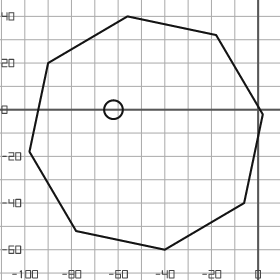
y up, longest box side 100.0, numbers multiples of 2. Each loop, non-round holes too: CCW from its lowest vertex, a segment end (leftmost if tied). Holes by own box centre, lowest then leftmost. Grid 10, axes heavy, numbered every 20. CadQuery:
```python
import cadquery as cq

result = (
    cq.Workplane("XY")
    .moveTo(-40.0, -60.0)
    .lineTo(-6.0, -40.0)
    .lineTo(2.0, -2.0)
    .lineTo(-18.0, 32.0)
    .lineTo(-56.0, 40.0)
    .lineTo(-90.0, 20.0)
    .lineTo(-98.0, -18.0)
    .lineTo(-78.0, -52.0)
    .close()
    .moveTo(-62.0, 0.0)
    .circle(4.0)
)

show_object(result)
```